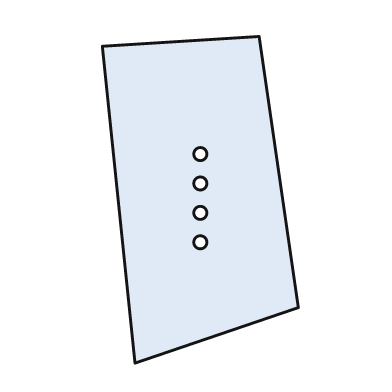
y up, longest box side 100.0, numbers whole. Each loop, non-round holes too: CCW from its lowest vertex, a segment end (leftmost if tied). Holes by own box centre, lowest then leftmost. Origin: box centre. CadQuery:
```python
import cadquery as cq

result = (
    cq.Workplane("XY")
    .moveTo(-20.0, -50.0)
    .lineTo(30.0, -33.0)
    .lineTo(18.0, 50.0)
    .lineTo(-30.0, 47.0)
    .close()
    .moveTo(0.0, -13.0)
    .circle(2.0)
    .moveTo(0.0, -4.0)
    .circle(2.0)
    .moveTo(0.0, 5.0)
    .circle(2.0)
    .moveTo(0.0, 14.0)
    .circle(2.0)
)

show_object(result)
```